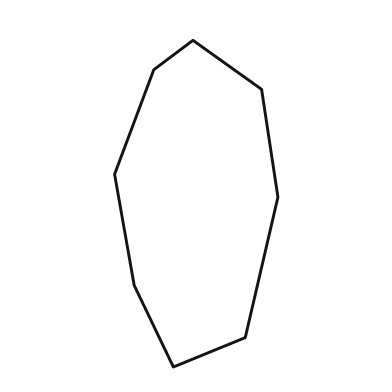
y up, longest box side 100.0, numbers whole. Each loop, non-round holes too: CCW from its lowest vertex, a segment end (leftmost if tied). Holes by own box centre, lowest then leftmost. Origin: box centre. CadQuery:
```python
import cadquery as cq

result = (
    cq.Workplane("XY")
    .moveTo(-7.0, -50.0)
    .lineTo(15.0, -41.0)
    .lineTo(25.0, 2.0)
    .lineTo(20.0, 35.0)
    .lineTo(-1.0, 50.0)
    .lineTo(-13.0, 41.0)
    .lineTo(-25.0, 9.0)
    .lineTo(-19.0, -25.0)
    .close()
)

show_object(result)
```